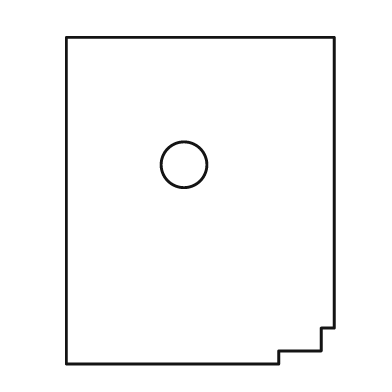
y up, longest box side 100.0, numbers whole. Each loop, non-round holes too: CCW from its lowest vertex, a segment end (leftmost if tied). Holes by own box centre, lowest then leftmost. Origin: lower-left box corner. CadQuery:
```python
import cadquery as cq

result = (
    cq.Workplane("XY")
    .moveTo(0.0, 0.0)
    .lineTo(65.0, 0.0)
    .lineTo(65.0, 4.0)
    .lineTo(78.0, 4.0)
    .lineTo(78.0, 11.0)
    .lineTo(82.0, 11.0)
    .lineTo(82.0, 100.0)
    .lineTo(0.0, 100.0)
    .close()
    .moveTo(36.0, 61.0)
    .circle(7.0)
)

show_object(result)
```